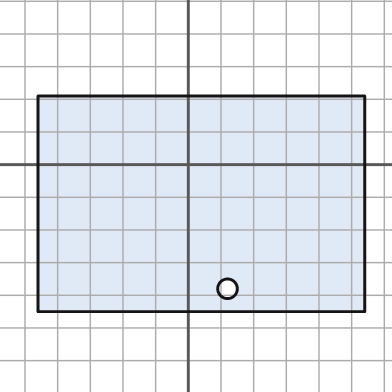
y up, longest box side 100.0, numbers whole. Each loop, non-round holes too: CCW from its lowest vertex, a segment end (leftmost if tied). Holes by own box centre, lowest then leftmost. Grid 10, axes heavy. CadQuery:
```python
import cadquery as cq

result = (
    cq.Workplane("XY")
    .moveTo(-46.0, -45.0)
    .lineTo(54.0, -45.0)
    .lineTo(54.0, 21.0)
    .lineTo(-46.0, 21.0)
    .close()
    .moveTo(12.0, -38.0)
    .circle(3.0)
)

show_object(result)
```